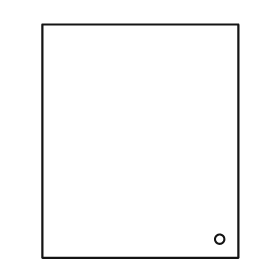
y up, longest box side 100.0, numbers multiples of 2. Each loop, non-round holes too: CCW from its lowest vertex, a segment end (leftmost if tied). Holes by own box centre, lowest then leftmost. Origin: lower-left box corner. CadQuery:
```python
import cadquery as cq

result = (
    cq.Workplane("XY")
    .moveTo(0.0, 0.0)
    .lineTo(84.0, 0.0)
    .lineTo(84.0, 100.0)
    .lineTo(0.0, 100.0)
    .close()
    .moveTo(76.0, 8.0)
    .circle(2.0)
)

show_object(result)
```